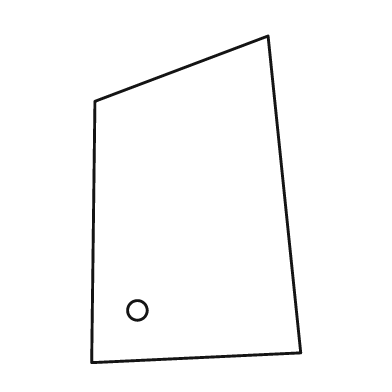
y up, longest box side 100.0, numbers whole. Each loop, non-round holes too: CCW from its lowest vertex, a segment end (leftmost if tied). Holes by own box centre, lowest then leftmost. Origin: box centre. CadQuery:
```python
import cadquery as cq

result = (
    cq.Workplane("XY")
    .moveTo(-32.0, -50.0)
    .lineTo(32.0, -47.0)
    .lineTo(22.0, 50.0)
    .lineTo(-31.0, 30.0)
    .close()
    .moveTo(-18.0, -34.0)
    .circle(3.0)
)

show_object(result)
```